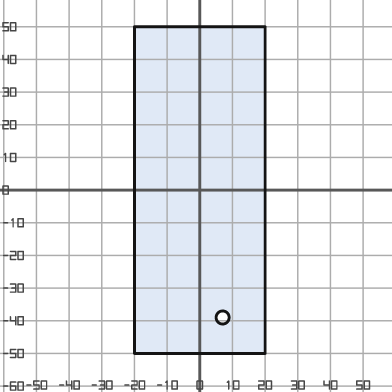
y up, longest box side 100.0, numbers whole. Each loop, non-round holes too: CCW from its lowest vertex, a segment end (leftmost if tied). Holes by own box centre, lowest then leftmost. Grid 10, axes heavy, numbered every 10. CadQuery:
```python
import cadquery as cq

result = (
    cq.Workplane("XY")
    .moveTo(-20.0, -50.0)
    .lineTo(20.0, -50.0)
    .lineTo(20.0, 50.0)
    .lineTo(-20.0, 50.0)
    .close()
    .moveTo(7.0, -39.0)
    .circle(2.0)
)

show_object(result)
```